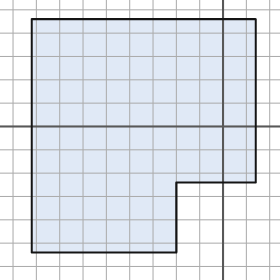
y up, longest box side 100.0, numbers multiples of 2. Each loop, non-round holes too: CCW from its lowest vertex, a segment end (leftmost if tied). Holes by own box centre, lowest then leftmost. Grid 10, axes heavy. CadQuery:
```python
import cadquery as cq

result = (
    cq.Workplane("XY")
    .moveTo(-82.0, -54.0)
    .lineTo(-20.0, -54.0)
    .lineTo(-20.0, -24.0)
    .lineTo(14.0, -24.0)
    .lineTo(14.0, 46.0)
    .lineTo(-82.0, 46.0)
    .close()
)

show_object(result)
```